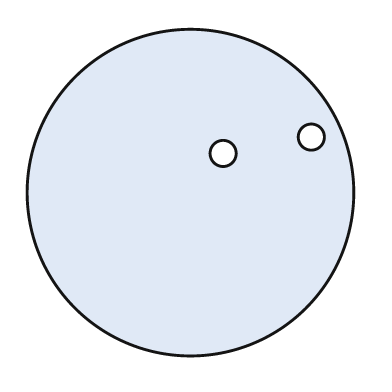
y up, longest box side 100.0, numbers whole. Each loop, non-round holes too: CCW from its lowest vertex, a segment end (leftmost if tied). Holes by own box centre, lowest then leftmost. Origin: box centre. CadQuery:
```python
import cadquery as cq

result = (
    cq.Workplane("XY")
    .moveTo(0.0, 0.0)
    .circle(50.0)
    .moveTo(10.0, 12.0)
    .circle(4.0)
    .moveTo(37.0, 17.0)
    .circle(4.0)
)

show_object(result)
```